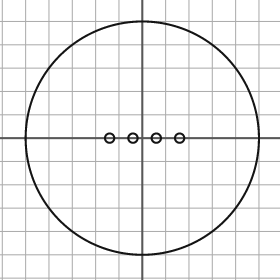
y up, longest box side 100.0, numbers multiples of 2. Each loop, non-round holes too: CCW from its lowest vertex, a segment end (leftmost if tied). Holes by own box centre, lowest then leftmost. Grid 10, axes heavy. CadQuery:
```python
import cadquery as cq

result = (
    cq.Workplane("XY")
    .moveTo(0.0, 0.0)
    .circle(50.0)
    .moveTo(-14.0, 0.0)
    .circle(2.0)
    .moveTo(-4.0, 0.0)
    .circle(2.0)
    .moveTo(6.0, 0.0)
    .circle(2.0)
    .moveTo(16.0, 0.0)
    .circle(2.0)
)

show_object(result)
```